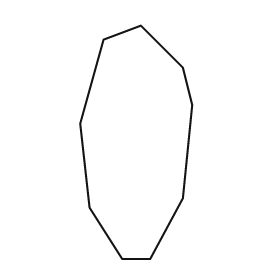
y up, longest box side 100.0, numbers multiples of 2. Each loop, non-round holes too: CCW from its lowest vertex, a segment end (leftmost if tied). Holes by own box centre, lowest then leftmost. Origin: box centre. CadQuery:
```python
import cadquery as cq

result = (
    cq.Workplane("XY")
    .moveTo(-6.0, -50.0)
    .lineTo(6.0, -50.0)
    .lineTo(20.0, -24.0)
    .lineTo(24.0, 16.0)
    .lineTo(20.0, 32.0)
    .lineTo(2.0, 50.0)
    .lineTo(-14.0, 44.0)
    .lineTo(-24.0, 8.0)
    .lineTo(-20.0, -28.0)
    .close()
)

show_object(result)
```